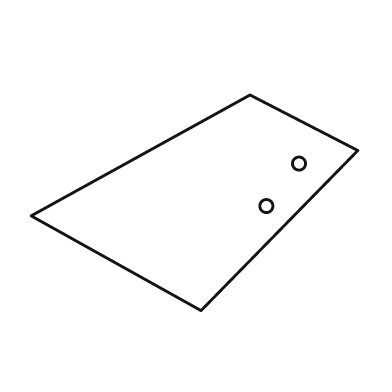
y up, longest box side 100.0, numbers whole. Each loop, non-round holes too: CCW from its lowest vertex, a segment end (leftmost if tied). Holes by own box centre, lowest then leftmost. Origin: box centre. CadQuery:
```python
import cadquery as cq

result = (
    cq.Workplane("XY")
    .moveTo(2.0, -33.0)
    .lineTo(50.0, 16.0)
    .lineTo(17.0, 33.0)
    .lineTo(-50.0, -4.0)
    .close()
    .moveTo(22.0, -1.0)
    .circle(2.0)
    .moveTo(32.0, 12.0)
    .circle(2.0)
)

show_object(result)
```